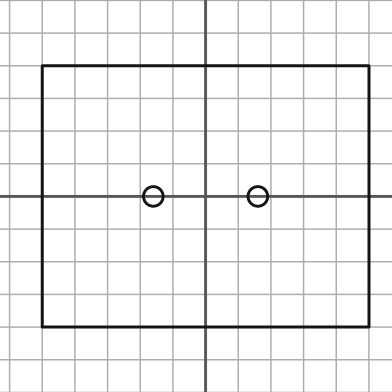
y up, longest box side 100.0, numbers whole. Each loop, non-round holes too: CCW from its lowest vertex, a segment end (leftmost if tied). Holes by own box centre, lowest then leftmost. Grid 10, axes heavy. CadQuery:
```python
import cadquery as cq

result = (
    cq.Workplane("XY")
    .moveTo(-50.0, -40.0)
    .lineTo(50.0, -40.0)
    .lineTo(50.0, 40.0)
    .lineTo(-50.0, 40.0)
    .close()
    .moveTo(-16.0, 0.0)
    .circle(3.0)
    .moveTo(16.0, 0.0)
    .circle(3.0)
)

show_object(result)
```